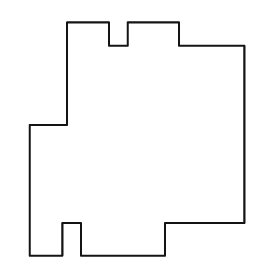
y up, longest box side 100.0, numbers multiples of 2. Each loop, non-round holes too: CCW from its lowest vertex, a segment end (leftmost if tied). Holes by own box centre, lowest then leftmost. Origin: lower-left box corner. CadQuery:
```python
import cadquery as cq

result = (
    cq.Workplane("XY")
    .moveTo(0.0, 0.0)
    .lineTo(14.0, 0.0)
    .lineTo(14.0, 14.0)
    .lineTo(22.0, 14.0)
    .lineTo(22.0, 0.0)
    .lineTo(58.0, 0.0)
    .lineTo(58.0, 14.0)
    .lineTo(92.0, 14.0)
    .lineTo(92.0, 90.0)
    .lineTo(64.0, 90.0)
    .lineTo(64.0, 100.0)
    .lineTo(42.0, 100.0)
    .lineTo(42.0, 90.0)
    .lineTo(34.0, 90.0)
    .lineTo(34.0, 100.0)
    .lineTo(16.0, 100.0)
    .lineTo(16.0, 56.0)
    .lineTo(0.0, 56.0)
    .close()
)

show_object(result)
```